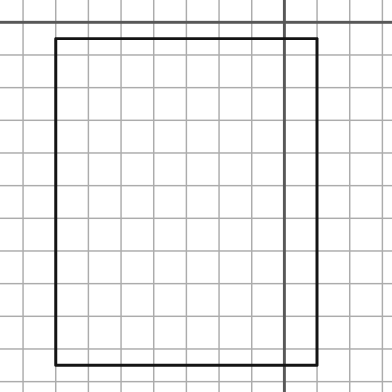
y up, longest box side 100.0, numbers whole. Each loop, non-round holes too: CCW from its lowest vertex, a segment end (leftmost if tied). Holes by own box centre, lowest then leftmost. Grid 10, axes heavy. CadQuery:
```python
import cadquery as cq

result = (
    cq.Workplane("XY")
    .moveTo(-70.0, -105.0)
    .lineTo(10.0, -105.0)
    .lineTo(10.0, -5.0)
    .lineTo(-70.0, -5.0)
    .close()
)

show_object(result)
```